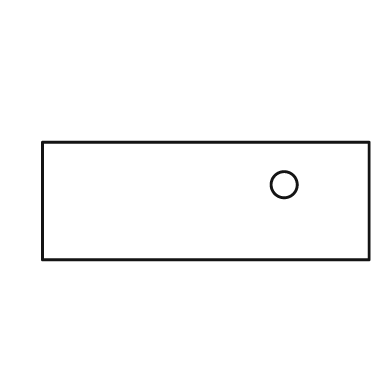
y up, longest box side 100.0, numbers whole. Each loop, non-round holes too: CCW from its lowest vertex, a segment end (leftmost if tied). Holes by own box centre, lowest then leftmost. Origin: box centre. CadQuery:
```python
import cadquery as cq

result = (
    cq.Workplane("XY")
    .moveTo(-50.0, -18.0)
    .lineTo(50.0, -18.0)
    .lineTo(50.0, 18.0)
    .lineTo(-50.0, 18.0)
    .close()
    .moveTo(24.0, 5.0)
    .circle(4.0)
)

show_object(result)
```